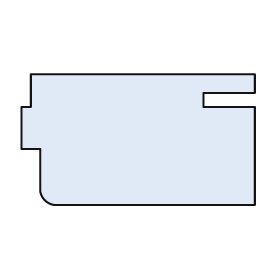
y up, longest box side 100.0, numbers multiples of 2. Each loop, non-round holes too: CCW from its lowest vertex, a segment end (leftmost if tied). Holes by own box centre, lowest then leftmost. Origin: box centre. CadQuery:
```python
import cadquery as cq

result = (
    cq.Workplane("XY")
    .moveTo(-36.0, -28.0)
    .lineTo(50.0, -28.0)
    .lineTo(50.0, 14.0)
    .lineTo(28.0, 14.0)
    .lineTo(28.0, 20.0)
    .lineTo(50.0, 20.0)
    .lineTo(50.0, 28.0)
    .lineTo(-46.0, 28.0)
    .lineTo(-46.0, 14.0)
    .lineTo(-50.0, 14.0)
    .lineTo(-50.0, -4.0)
    .lineTo(-42.0, -4.0)
    .lineTo(-42.0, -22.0)
    .threePointArc((-40.0, -26.0), (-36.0, -28.0))
    .close()
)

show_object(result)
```